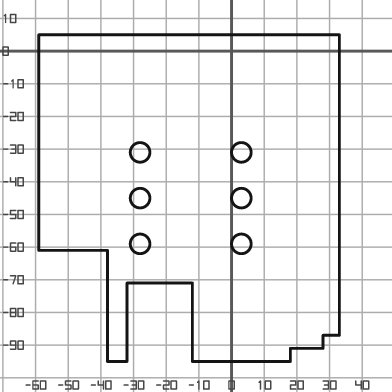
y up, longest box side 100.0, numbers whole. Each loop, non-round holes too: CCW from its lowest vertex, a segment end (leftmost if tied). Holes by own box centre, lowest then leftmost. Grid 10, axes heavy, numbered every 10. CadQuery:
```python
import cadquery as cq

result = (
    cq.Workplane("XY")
    .moveTo(-38.0, -95.0)
    .lineTo(-32.0, -95.0)
    .lineTo(-32.0, -71.0)
    .lineTo(-12.0, -71.0)
    .lineTo(-12.0, -95.0)
    .lineTo(18.0, -95.0)
    .lineTo(18.0, -91.0)
    .lineTo(28.0, -91.0)
    .lineTo(28.0, -87.0)
    .lineTo(33.0, -87.0)
    .lineTo(33.0, 5.0)
    .lineTo(-59.0, 5.0)
    .lineTo(-59.0, -61.0)
    .lineTo(-38.0, -61.0)
    .close()
    .moveTo(-28.0, -59.0)
    .circle(3.0)
    .moveTo(3.0, -59.0)
    .circle(3.0)
    .moveTo(-28.0, -45.0)
    .circle(3.0)
    .moveTo(3.0, -45.0)
    .circle(3.0)
    .moveTo(-28.0, -31.0)
    .circle(3.0)
    .moveTo(3.0, -31.0)
    .circle(3.0)
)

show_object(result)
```